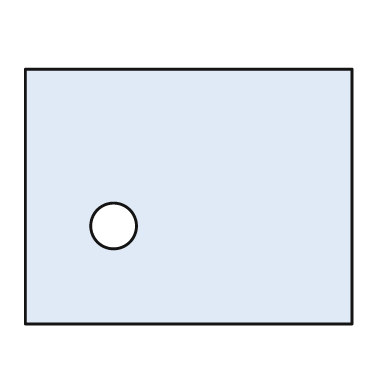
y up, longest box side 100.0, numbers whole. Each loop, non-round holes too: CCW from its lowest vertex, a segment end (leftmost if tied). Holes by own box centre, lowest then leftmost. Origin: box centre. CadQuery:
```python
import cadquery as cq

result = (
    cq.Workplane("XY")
    .moveTo(-50.0, -39.0)
    .lineTo(50.0, -39.0)
    .lineTo(50.0, 39.0)
    .lineTo(-50.0, 39.0)
    .close()
    .moveTo(-23.0, -9.0)
    .circle(7.0)
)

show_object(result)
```